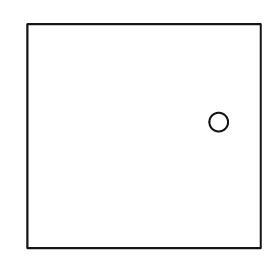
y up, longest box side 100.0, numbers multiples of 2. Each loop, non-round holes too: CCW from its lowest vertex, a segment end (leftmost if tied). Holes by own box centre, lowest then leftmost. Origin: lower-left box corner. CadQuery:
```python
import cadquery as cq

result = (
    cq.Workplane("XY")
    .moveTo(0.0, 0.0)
    .lineTo(100.0, 0.0)
    .lineTo(100.0, 96.0)
    .lineTo(0.0, 96.0)
    .close()
    .moveTo(82.0, 54.0)
    .circle(4.0)
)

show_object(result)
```